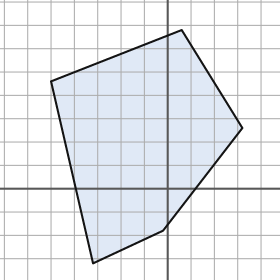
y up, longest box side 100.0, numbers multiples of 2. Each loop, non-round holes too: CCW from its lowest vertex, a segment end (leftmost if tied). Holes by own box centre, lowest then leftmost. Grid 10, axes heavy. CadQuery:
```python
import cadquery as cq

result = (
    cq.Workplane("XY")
    .moveTo(-32.0, -32.0)
    .lineTo(-2.0, -18.0)
    .lineTo(32.0, 26.0)
    .lineTo(6.0, 68.0)
    .lineTo(-50.0, 46.0)
    .close()
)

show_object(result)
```